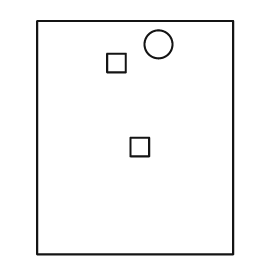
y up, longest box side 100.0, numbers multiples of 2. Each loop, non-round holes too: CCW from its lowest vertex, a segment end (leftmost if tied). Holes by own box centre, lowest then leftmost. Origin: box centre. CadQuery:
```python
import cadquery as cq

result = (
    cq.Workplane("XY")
    .moveTo(-42.0, -50.0)
    .lineTo(42.0, -50.0)
    .lineTo(42.0, 50.0)
    .lineTo(-42.0, 50.0)
    .close()
    .moveTo(-2.0, -8.0)
    .lineTo(6.0, -8.0)
    .lineTo(6.0, 0.0)
    .lineTo(-2.0, 0.0)
    .close()
    .moveTo(-12.0, 28.0)
    .lineTo(-4.0, 28.0)
    .lineTo(-4.0, 36.0)
    .lineTo(-12.0, 36.0)
    .close()
    .moveTo(10.0, 40.0)
    .circle(6.0)
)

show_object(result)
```